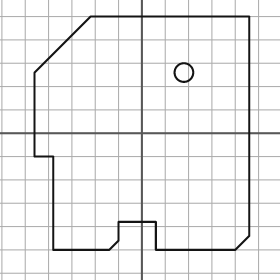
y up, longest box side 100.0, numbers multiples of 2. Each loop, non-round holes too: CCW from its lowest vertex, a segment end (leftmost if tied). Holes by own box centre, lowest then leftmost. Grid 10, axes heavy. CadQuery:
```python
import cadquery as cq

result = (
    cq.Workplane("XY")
    .moveTo(-38.0, -50.0)
    .lineTo(-14.0, -50.0)
    .lineTo(-10.0, -46.0)
    .lineTo(-10.0, -38.0)
    .lineTo(6.0, -38.0)
    .lineTo(6.0, -50.0)
    .lineTo(40.0, -50.0)
    .lineTo(46.0, -44.0)
    .lineTo(46.0, 50.0)
    .lineTo(-22.0, 50.0)
    .lineTo(-46.0, 26.0)
    .lineTo(-46.0, -10.0)
    .lineTo(-38.0, -10.0)
    .close()
    .moveTo(18.0, 26.0)
    .circle(4.0)
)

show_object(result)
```